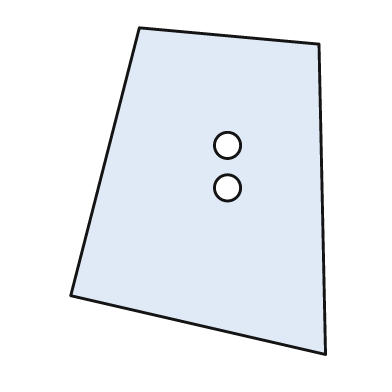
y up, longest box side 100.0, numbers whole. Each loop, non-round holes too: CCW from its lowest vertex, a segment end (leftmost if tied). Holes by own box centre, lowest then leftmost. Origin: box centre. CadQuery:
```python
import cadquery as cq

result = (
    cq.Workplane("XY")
    .moveTo(39.0, -50.0)
    .lineTo(37.0, 45.0)
    .lineTo(-18.0, 50.0)
    .lineTo(-39.0, -32.0)
    .close()
    .moveTo(9.0, 1.0)
    .circle(4.0)
    .moveTo(9.0, 14.0)
    .circle(4.0)
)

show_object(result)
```